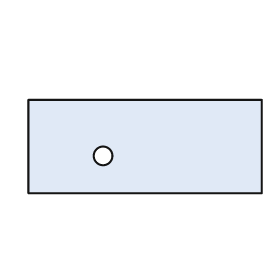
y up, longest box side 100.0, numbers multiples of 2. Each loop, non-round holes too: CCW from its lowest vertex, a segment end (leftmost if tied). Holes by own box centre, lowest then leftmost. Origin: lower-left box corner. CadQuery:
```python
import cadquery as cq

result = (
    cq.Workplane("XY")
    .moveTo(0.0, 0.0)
    .lineTo(100.0, 0.0)
    .lineTo(100.0, 40.0)
    .lineTo(0.0, 40.0)
    .close()
    .moveTo(32.0, 16.0)
    .circle(4.0)
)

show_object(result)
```